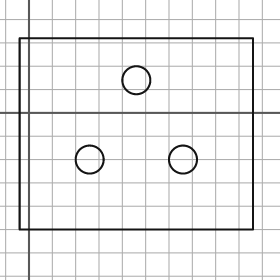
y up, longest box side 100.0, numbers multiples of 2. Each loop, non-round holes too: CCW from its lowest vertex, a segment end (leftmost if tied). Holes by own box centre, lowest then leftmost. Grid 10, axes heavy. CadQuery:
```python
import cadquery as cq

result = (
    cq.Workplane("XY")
    .moveTo(-4.0, -50.0)
    .lineTo(96.0, -50.0)
    .lineTo(96.0, 32.0)
    .lineTo(-4.0, 32.0)
    .close()
    .moveTo(26.0, -20.0)
    .circle(6.0)
    .moveTo(66.0, -20.0)
    .circle(6.0)
    .moveTo(46.0, 14.0)
    .circle(6.0)
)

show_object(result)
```